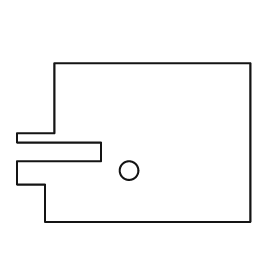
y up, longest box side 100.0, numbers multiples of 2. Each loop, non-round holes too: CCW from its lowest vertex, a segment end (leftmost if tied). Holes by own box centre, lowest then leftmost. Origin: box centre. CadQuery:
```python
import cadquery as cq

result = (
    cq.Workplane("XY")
    .moveTo(-38.0, -34.0)
    .lineTo(50.0, -34.0)
    .lineTo(50.0, 34.0)
    .lineTo(-34.0, 34.0)
    .lineTo(-34.0, 4.0)
    .lineTo(-50.0, 4.0)
    .lineTo(-50.0, 0.0)
    .lineTo(-14.0, 0.0)
    .lineTo(-14.0, -8.0)
    .lineTo(-50.0, -8.0)
    .lineTo(-50.0, -18.0)
    .lineTo(-38.0, -18.0)
    .close()
    .moveTo(-2.0, -12.0)
    .circle(4.0)
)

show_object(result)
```